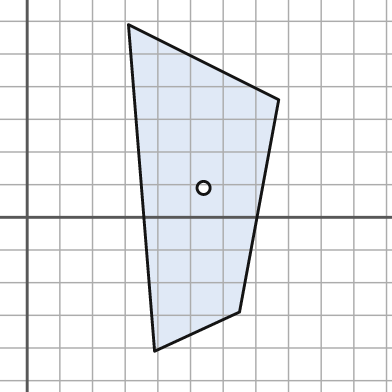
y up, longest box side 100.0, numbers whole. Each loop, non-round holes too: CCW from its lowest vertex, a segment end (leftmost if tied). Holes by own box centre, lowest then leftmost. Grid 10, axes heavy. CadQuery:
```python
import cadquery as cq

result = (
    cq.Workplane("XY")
    .moveTo(39.0, -41.0)
    .lineTo(65.0, -29.0)
    .lineTo(77.0, 36.0)
    .lineTo(31.0, 59.0)
    .close()
    .moveTo(54.0, 9.0)
    .circle(2.0)
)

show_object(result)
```